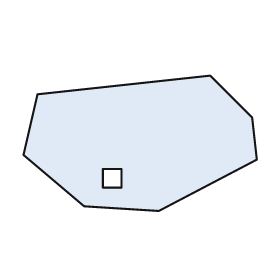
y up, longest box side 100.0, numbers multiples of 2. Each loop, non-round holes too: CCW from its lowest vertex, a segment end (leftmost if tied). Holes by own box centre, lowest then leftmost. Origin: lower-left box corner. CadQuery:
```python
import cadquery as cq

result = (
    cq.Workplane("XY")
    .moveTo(58.0, 0.0)
    .lineTo(100.0, 22.0)
    .lineTo(98.0, 40.0)
    .lineTo(80.0, 58.0)
    .lineTo(6.0, 50.0)
    .lineTo(0.0, 24.0)
    .lineTo(26.0, 2.0)
    .close()
    .moveTo(34.0, 10.0)
    .lineTo(42.0, 10.0)
    .lineTo(42.0, 18.0)
    .lineTo(34.0, 18.0)
    .close()
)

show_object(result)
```